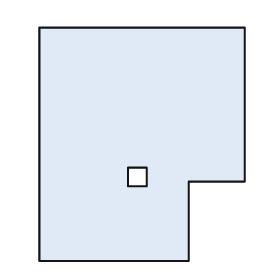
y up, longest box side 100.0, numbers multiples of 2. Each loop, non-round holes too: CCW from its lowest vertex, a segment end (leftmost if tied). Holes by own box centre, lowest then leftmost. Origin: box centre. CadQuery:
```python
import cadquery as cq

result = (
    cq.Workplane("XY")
    .moveTo(-44.0, -50.0)
    .lineTo(20.0, -50.0)
    .lineTo(20.0, -16.0)
    .lineTo(44.0, -16.0)
    .lineTo(44.0, 50.0)
    .lineTo(-44.0, 50.0)
    .close()
    .moveTo(-6.0, -18.0)
    .lineTo(2.0, -18.0)
    .lineTo(2.0, -10.0)
    .lineTo(-6.0, -10.0)
    .close()
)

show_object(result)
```